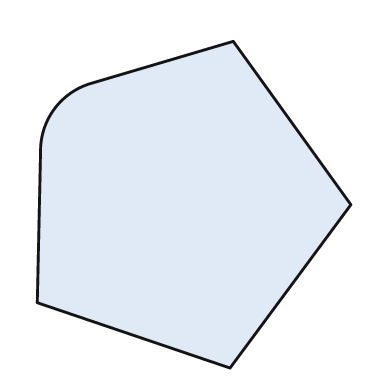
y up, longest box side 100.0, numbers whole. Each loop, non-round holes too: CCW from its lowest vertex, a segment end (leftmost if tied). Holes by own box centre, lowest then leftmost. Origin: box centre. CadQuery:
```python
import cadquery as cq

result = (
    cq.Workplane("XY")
    .moveTo(11.0, -50.0)
    .lineTo(48.0, 0.0)
    .lineTo(12.0, 50.0)
    .lineTo(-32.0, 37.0)
    .threePointArc((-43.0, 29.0), (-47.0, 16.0))
    .lineTo(-48.0, -30.0)
    .close()
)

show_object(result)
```